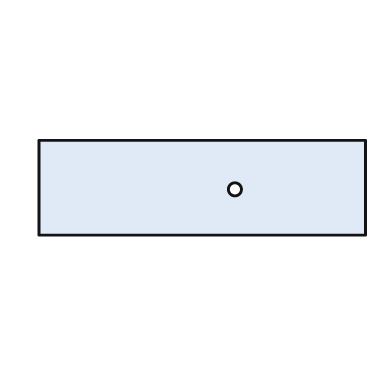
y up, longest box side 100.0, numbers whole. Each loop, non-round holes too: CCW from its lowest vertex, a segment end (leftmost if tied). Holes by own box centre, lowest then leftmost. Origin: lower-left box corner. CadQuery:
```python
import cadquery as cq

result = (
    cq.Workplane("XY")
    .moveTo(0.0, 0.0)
    .lineTo(100.0, 0.0)
    .lineTo(100.0, 29.0)
    .lineTo(0.0, 29.0)
    .close()
    .moveTo(60.0, 14.0)
    .circle(2.0)
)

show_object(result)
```